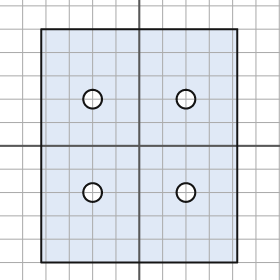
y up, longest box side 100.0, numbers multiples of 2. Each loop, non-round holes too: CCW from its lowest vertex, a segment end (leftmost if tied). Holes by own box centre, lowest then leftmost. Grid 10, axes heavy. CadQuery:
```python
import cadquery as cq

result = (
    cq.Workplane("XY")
    .moveTo(-42.0, -50.0)
    .lineTo(42.0, -50.0)
    .lineTo(42.0, 50.0)
    .lineTo(-42.0, 50.0)
    .close()
    .moveTo(-20.0, -20.0)
    .circle(4.0)
    .moveTo(20.0, -20.0)
    .circle(4.0)
    .moveTo(-20.0, 20.0)
    .circle(4.0)
    .moveTo(20.0, 20.0)
    .circle(4.0)
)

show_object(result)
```